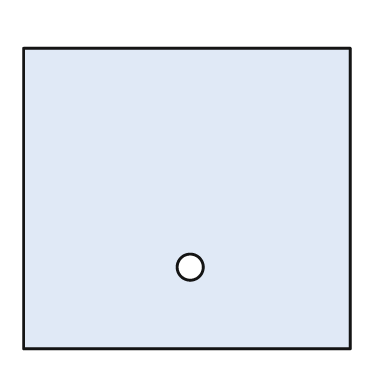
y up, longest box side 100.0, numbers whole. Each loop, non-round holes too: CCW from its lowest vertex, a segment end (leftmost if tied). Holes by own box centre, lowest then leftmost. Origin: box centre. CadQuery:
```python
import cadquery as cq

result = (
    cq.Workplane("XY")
    .moveTo(-50.0, -46.0)
    .lineTo(50.0, -46.0)
    .lineTo(50.0, 46.0)
    .lineTo(-50.0, 46.0)
    .close()
    .moveTo(1.0, -21.0)
    .circle(4.0)
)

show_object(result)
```